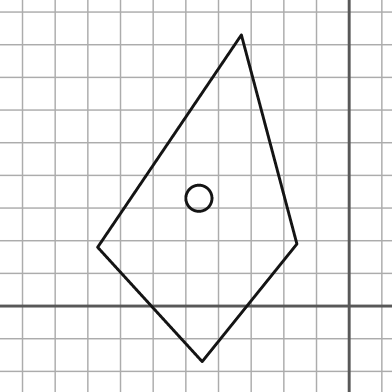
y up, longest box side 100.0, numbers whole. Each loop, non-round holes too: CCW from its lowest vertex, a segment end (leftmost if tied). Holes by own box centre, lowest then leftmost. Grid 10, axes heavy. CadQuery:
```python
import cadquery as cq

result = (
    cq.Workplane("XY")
    .moveTo(-45.0, -17.0)
    .lineTo(-16.0, 19.0)
    .lineTo(-33.0, 83.0)
    .lineTo(-77.0, 18.0)
    .close()
    .moveTo(-46.0, 33.0)
    .circle(4.0)
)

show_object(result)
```